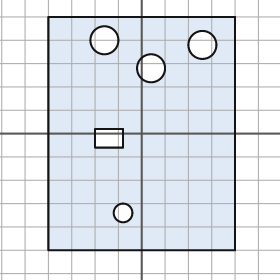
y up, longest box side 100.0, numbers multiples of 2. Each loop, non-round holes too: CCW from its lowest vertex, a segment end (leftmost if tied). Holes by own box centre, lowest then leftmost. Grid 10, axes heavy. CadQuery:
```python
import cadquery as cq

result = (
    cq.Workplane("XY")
    .moveTo(-40.0, -50.0)
    .lineTo(40.0, -50.0)
    .lineTo(40.0, 50.0)
    .lineTo(-40.0, 50.0)
    .close()
    .moveTo(-8.0, -34.0)
    .circle(4.0)
    .moveTo(-20.0, -6.0)
    .lineTo(-8.0, -6.0)
    .lineTo(-8.0, 2.0)
    .lineTo(-20.0, 2.0)
    .close()
    .moveTo(4.0, 28.0)
    .circle(6.0)
    .moveTo(26.0, 38.0)
    .circle(6.0)
    .moveTo(-16.0, 40.0)
    .circle(6.0)
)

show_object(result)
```